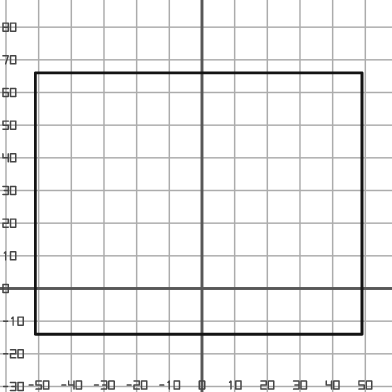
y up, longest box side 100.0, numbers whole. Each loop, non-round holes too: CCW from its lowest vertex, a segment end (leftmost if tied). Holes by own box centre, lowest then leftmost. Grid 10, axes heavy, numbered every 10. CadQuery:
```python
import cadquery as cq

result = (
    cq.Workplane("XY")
    .moveTo(-51.0, -14.0)
    .lineTo(49.0, -14.0)
    .lineTo(49.0, 66.0)
    .lineTo(-51.0, 66.0)
    .close()
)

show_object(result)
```